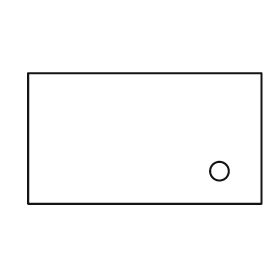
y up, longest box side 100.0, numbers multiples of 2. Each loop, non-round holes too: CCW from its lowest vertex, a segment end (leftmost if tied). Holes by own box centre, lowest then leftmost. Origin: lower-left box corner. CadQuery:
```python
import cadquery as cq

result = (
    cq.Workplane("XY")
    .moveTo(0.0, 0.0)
    .lineTo(100.0, 0.0)
    .lineTo(100.0, 56.0)
    .lineTo(0.0, 56.0)
    .close()
    .moveTo(82.0, 14.0)
    .circle(4.0)
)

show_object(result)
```